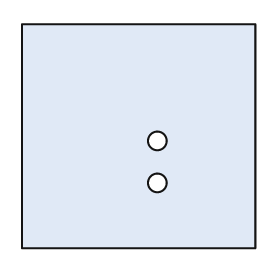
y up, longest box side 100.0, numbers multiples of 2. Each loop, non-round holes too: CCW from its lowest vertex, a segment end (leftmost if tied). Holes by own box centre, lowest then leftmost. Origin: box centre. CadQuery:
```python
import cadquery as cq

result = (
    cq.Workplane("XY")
    .moveTo(-50.0, -48.0)
    .lineTo(50.0, -48.0)
    .lineTo(50.0, 48.0)
    .lineTo(-50.0, 48.0)
    .close()
    .moveTo(8.0, -20.0)
    .circle(4.0)
    .moveTo(8.0, -2.0)
    .circle(4.0)
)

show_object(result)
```